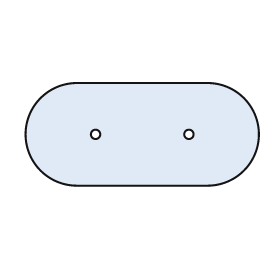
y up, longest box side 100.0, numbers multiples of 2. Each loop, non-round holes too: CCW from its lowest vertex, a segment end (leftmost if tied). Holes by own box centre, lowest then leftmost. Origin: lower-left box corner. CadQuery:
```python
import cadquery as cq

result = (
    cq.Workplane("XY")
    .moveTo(22.0, 0.0)
    .lineTo(78.0, 0.0)
    .threePointArc((100.0, 22.0), (78.0, 44.0))
    .lineTo(22.0, 44.0)
    .threePointArc((0.0, 22.0), (22.0, 0.0))
    .close()
    .moveTo(30.0, 22.0)
    .circle(2.0)
    .moveTo(70.0, 22.0)
    .circle(2.0)
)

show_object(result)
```